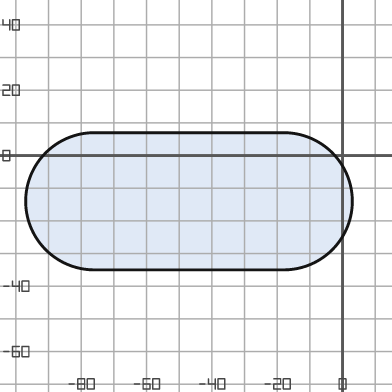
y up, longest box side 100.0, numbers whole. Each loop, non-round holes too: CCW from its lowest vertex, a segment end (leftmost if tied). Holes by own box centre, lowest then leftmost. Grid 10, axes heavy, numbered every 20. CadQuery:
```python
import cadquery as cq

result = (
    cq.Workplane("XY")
    .moveTo(-76.0, -35.0)
    .lineTo(-18.0, -35.0)
    .threePointArc((3.0, -14.0), (-18.0, 7.0))
    .lineTo(-76.0, 7.0)
    .threePointArc((-97.0, -14.0), (-76.0, -35.0))
    .close()
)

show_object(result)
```